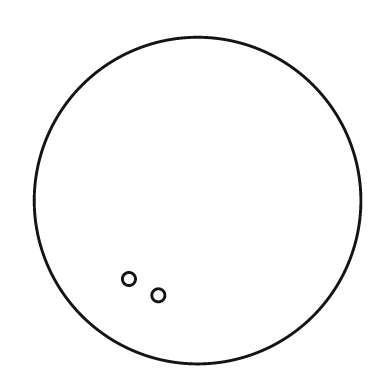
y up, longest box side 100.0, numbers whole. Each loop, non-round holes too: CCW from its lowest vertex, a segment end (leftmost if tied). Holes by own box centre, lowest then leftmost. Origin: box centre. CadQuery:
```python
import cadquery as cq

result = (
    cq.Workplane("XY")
    .moveTo(0.0, 0.0)
    .circle(50.0)
    .moveTo(-12.0, -29.0)
    .circle(2.0)
    .moveTo(-21.0, -24.0)
    .circle(2.0)
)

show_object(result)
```